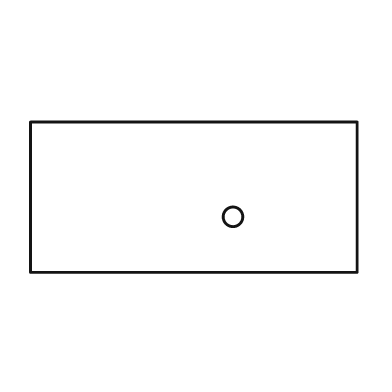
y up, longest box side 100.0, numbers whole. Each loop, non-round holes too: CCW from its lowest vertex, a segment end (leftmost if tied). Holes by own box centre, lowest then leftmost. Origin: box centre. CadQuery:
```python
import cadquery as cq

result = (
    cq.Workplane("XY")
    .moveTo(-50.0, -23.0)
    .lineTo(50.0, -23.0)
    .lineTo(50.0, 23.0)
    .lineTo(-50.0, 23.0)
    .close()
    .moveTo(12.0, -6.0)
    .circle(3.0)
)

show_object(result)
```